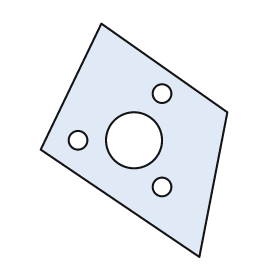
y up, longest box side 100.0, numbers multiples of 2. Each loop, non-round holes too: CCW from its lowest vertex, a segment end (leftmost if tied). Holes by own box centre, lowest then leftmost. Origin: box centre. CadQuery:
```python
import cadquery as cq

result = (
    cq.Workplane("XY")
    .moveTo(28.0, -50.0)
    .lineTo(40.0, 12.0)
    .lineTo(-14.0, 50.0)
    .lineTo(-40.0, -4.0)
    .close()
    .moveTo(12.0, -20.0)
    .circle(4.0)
    .moveTo(-24.0, 0.0)
    .circle(4.0)
    .moveTo(0.0, 0.0)
    .circle(12.0)
    .moveTo(12.0, 20.0)
    .circle(4.0)
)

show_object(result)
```